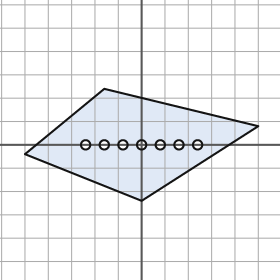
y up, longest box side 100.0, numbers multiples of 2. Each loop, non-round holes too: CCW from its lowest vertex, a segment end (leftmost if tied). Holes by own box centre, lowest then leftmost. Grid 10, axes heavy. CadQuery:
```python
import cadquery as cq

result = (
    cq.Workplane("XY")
    .moveTo(0.0, -24.0)
    .lineTo(50.0, 8.0)
    .lineTo(-16.0, 24.0)
    .lineTo(-50.0, -4.0)
    .close()
    .moveTo(-24.0, 0.0)
    .circle(2.0)
    .moveTo(-16.0, 0.0)
    .circle(2.0)
    .moveTo(-8.0, 0.0)
    .circle(2.0)
    .moveTo(0.0, 0.0)
    .circle(2.0)
    .moveTo(8.0, 0.0)
    .circle(2.0)
    .moveTo(16.0, 0.0)
    .circle(2.0)
    .moveTo(24.0, 0.0)
    .circle(2.0)
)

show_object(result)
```